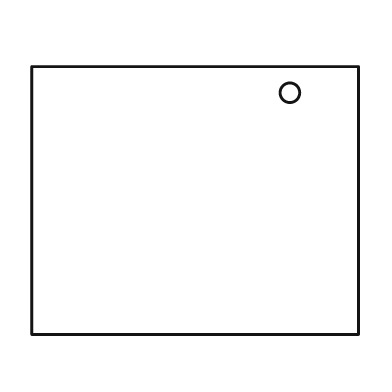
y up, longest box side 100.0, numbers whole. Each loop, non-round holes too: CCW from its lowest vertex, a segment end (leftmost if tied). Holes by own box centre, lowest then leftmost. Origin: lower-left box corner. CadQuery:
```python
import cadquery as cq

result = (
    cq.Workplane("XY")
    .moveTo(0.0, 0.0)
    .lineTo(100.0, 0.0)
    .lineTo(100.0, 82.0)
    .lineTo(0.0, 82.0)
    .close()
    .moveTo(79.0, 74.0)
    .circle(3.0)
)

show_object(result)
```